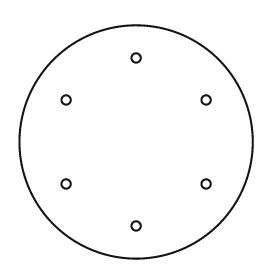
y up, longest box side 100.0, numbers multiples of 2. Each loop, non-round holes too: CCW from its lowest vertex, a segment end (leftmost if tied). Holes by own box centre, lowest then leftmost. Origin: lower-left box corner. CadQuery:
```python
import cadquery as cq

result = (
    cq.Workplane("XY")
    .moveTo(50.0, 50.0)
    .circle(50.0)
    .moveTo(50.0, 14.0)
    .circle(2.0)
    .moveTo(20.0, 32.0)
    .circle(2.0)
    .moveTo(80.0, 32.0)
    .circle(2.0)
    .moveTo(20.0, 68.0)
    .circle(2.0)
    .moveTo(80.0, 68.0)
    .circle(2.0)
    .moveTo(50.0, 86.0)
    .circle(2.0)
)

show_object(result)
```